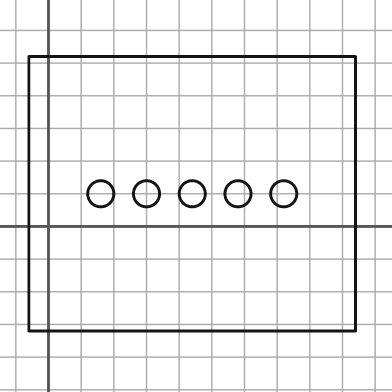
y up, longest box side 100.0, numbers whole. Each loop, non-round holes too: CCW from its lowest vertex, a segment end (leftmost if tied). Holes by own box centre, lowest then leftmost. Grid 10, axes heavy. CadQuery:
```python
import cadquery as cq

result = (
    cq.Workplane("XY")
    .moveTo(-6.0, -32.0)
    .lineTo(94.0, -32.0)
    .lineTo(94.0, 52.0)
    .lineTo(-6.0, 52.0)
    .close()
    .moveTo(16.0, 10.0)
    .circle(4.0)
    .moveTo(30.0, 10.0)
    .circle(4.0)
    .moveTo(44.0, 10.0)
    .circle(4.0)
    .moveTo(58.0, 10.0)
    .circle(4.0)
    .moveTo(72.0, 10.0)
    .circle(4.0)
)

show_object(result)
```